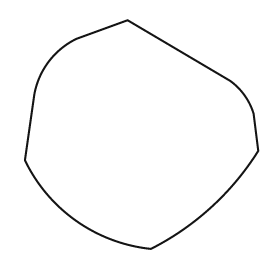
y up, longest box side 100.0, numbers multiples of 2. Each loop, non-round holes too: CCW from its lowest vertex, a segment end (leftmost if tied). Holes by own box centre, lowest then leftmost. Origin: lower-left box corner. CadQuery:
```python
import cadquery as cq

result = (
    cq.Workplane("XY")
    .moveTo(54.0, 0.0)
    .threePointArc((80.0, 18.0), (100.0, 42.0))
    .lineTo(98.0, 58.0)
    .threePointArc((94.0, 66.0), (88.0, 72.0))
    .lineTo(44.0, 98.0)
    .lineTo(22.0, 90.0)
    .threePointArc((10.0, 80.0), (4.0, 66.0))
    .lineTo(0.0, 38.0)
    .threePointArc((22.0, 12.0), (54.0, 0.0))
    .close()
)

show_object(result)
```